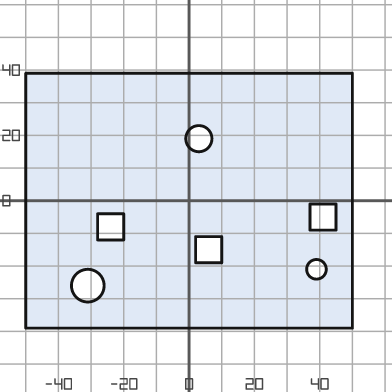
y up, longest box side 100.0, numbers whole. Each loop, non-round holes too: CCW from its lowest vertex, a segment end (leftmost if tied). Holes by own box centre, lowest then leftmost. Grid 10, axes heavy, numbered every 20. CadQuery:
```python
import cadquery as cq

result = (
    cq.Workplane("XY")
    .moveTo(-50.0, -39.0)
    .lineTo(50.0, -39.0)
    .lineTo(50.0, 39.0)
    .lineTo(-50.0, 39.0)
    .close()
    .moveTo(-31.0, -26.0)
    .circle(5.0)
    .moveTo(39.0, -21.0)
    .circle(3.0)
    .moveTo(2.0, -19.0)
    .lineTo(10.0, -19.0)
    .lineTo(10.0, -11.0)
    .lineTo(2.0, -11.0)
    .close()
    .moveTo(-28.0, -12.0)
    .lineTo(-20.0, -12.0)
    .lineTo(-20.0, -4.0)
    .lineTo(-28.0, -4.0)
    .close()
    .moveTo(37.0, -9.0)
    .lineTo(45.0, -9.0)
    .lineTo(45.0, -1.0)
    .lineTo(37.0, -1.0)
    .close()
    .moveTo(3.0, 19.0)
    .circle(4.0)
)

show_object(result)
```